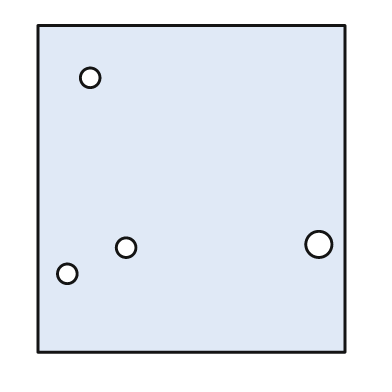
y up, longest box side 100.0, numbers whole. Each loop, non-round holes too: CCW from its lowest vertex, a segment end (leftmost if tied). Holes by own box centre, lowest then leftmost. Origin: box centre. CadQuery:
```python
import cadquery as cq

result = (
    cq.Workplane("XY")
    .moveTo(-47.0, -50.0)
    .lineTo(47.0, -50.0)
    .lineTo(47.0, 50.0)
    .lineTo(-47.0, 50.0)
    .close()
    .moveTo(-38.0, -26.0)
    .circle(3.0)
    .moveTo(-20.0, -18.0)
    .circle(3.0)
    .moveTo(39.0, -17.0)
    .circle(4.0)
    .moveTo(-31.0, 34.0)
    .circle(3.0)
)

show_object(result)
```